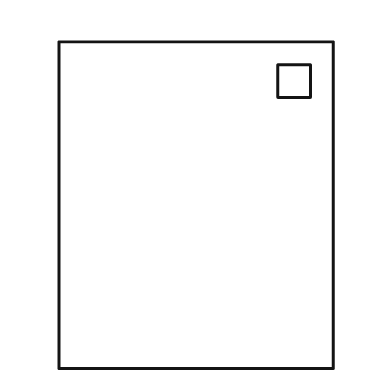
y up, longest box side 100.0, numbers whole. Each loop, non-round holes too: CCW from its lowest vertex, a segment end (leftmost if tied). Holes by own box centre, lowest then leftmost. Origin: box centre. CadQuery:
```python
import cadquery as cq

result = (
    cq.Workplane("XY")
    .moveTo(-42.0, -50.0)
    .lineTo(42.0, -50.0)
    .lineTo(42.0, 50.0)
    .lineTo(-42.0, 50.0)
    .close()
    .moveTo(25.0, 33.0)
    .lineTo(35.0, 33.0)
    .lineTo(35.0, 43.0)
    .lineTo(25.0, 43.0)
    .close()
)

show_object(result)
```